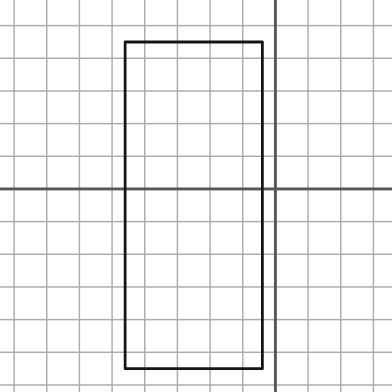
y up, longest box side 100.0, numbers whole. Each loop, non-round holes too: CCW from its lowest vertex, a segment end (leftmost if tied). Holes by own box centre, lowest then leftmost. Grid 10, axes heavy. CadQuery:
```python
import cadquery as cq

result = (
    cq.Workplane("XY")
    .moveTo(-46.0, -55.0)
    .lineTo(-4.0, -55.0)
    .lineTo(-4.0, 45.0)
    .lineTo(-46.0, 45.0)
    .close()
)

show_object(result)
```